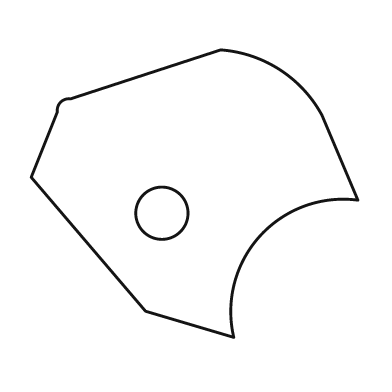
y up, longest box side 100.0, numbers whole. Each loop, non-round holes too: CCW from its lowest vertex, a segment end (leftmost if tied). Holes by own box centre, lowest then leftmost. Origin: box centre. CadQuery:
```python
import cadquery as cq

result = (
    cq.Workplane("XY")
    .moveTo(12.0, -44.0)
    .threePointArc((20.0, -13.0), (50.0, -2.0))
    .lineTo(39.0, 24.0)
    .threePointArc((26.0, 38.0), (8.0, 44.0))
    .lineTo(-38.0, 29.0)
    .threePointArc((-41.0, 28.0), (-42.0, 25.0))
    .lineTo(-50.0, 5.0)
    .lineTo(-15.0, -36.0)
    .close()
    .moveTo(-10.0, -6.0)
    .circle(8.0)
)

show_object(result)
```